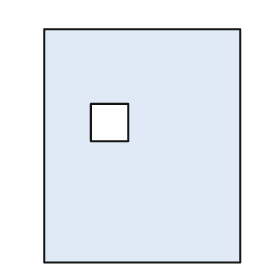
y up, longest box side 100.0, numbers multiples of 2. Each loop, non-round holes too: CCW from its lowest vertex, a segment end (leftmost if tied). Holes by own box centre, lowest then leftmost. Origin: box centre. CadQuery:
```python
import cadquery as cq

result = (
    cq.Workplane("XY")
    .moveTo(-42.0, -50.0)
    .lineTo(42.0, -50.0)
    .lineTo(42.0, 50.0)
    .lineTo(-42.0, 50.0)
    .close()
    .moveTo(-22.0, 2.0)
    .lineTo(-6.0, 2.0)
    .lineTo(-6.0, 18.0)
    .lineTo(-22.0, 18.0)
    .close()
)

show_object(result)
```